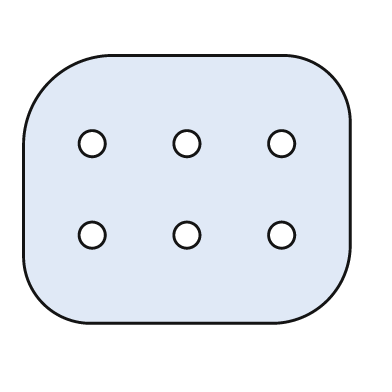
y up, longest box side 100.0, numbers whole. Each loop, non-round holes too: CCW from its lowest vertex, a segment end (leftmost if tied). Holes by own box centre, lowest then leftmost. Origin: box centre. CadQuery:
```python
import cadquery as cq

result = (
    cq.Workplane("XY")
    .moveTo(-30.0, -41.0)
    .lineTo(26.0, -41.0)
    .threePointArc((43.0, -34.0), (50.0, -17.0))
    .lineTo(50.0, 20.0)
    .threePointArc((44.0, 35.0), (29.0, 41.0))
    .lineTo(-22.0, 41.0)
    .threePointArc((-42.0, 33.0), (-50.0, 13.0))
    .lineTo(-50.0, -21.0)
    .threePointArc((-44.0, -35.0), (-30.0, -41.0))
    .close()
    .moveTo(-29.0, -14.0)
    .circle(4.0)
    .moveTo(0.0, -14.0)
    .circle(4.0)
    .moveTo(29.0, -14.0)
    .circle(4.0)
    .moveTo(-29.0, 14.0)
    .circle(4.0)
    .moveTo(0.0, 14.0)
    .circle(4.0)
    .moveTo(29.0, 14.0)
    .circle(4.0)
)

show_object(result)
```